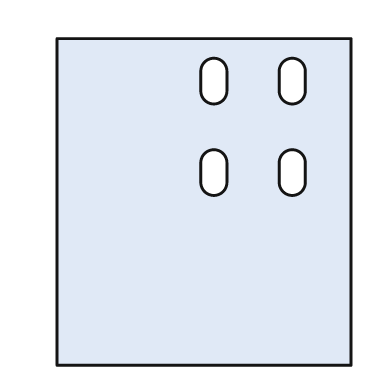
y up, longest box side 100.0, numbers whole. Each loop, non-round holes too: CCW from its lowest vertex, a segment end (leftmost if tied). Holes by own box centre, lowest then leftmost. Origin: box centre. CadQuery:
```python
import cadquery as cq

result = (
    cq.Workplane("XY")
    .moveTo(-45.0, -50.0)
    .lineTo(45.0, -50.0)
    .lineTo(45.0, 50.0)
    .lineTo(-45.0, 50.0)
    .close()
    .moveTo(-1.0, 6.0)
    .threePointArc((3.0, 2.0), (7.0, 6.0))
    .lineTo(7.0, 12.0)
    .threePointArc((3.0, 16.0), (-1.0, 12.0))
    .close()
    .moveTo(23.0, 6.0)
    .threePointArc((27.0, 2.0), (31.0, 6.0))
    .lineTo(31.0, 12.0)
    .threePointArc((27.0, 16.0), (23.0, 12.0))
    .close()
    .moveTo(-1.0, 34.0)
    .threePointArc((3.0, 30.0), (7.0, 34.0))
    .lineTo(7.0, 40.0)
    .threePointArc((3.0, 44.0), (-1.0, 40.0))
    .close()
    .moveTo(23.0, 34.0)
    .threePointArc((27.0, 30.0), (31.0, 34.0))
    .lineTo(31.0, 40.0)
    .threePointArc((27.0, 44.0), (23.0, 40.0))
    .close()
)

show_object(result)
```